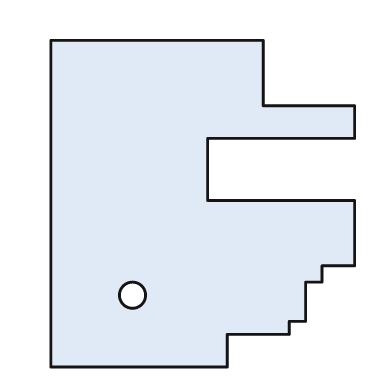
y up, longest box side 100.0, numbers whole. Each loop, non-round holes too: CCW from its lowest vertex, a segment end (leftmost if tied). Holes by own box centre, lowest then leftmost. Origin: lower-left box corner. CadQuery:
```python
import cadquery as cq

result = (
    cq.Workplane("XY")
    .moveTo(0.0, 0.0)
    .lineTo(54.0, 0.0)
    .lineTo(54.0, 10.0)
    .lineTo(73.0, 10.0)
    .lineTo(73.0, 14.0)
    .lineTo(78.0, 14.0)
    .lineTo(78.0, 26.0)
    .lineTo(83.0, 26.0)
    .lineTo(83.0, 31.0)
    .lineTo(93.0, 31.0)
    .lineTo(93.0, 51.0)
    .lineTo(48.0, 51.0)
    .lineTo(48.0, 70.0)
    .lineTo(93.0, 70.0)
    .lineTo(93.0, 80.0)
    .lineTo(65.0, 80.0)
    .lineTo(65.0, 100.0)
    .lineTo(0.0, 100.0)
    .close()
    .moveTo(25.0, 22.0)
    .circle(4.0)
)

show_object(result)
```